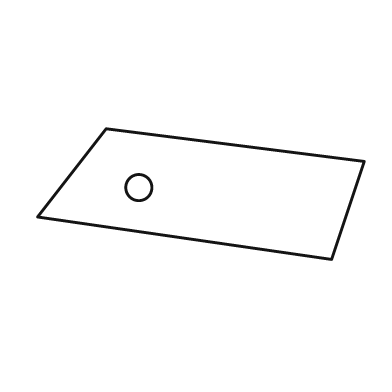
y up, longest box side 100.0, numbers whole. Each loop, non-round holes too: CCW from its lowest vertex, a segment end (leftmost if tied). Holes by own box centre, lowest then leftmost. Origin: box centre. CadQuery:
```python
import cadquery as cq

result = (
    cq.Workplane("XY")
    .moveTo(40.0, -20.0)
    .lineTo(50.0, 10.0)
    .lineTo(-29.0, 20.0)
    .lineTo(-50.0, -7.0)
    .close()
    .moveTo(-19.0, 2.0)
    .circle(4.0)
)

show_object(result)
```